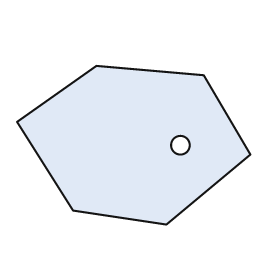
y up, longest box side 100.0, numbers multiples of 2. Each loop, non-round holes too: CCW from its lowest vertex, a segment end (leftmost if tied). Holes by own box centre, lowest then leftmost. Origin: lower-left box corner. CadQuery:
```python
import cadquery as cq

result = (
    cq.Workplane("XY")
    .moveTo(64.0, 0.0)
    .lineTo(100.0, 30.0)
    .lineTo(80.0, 64.0)
    .lineTo(34.0, 68.0)
    .lineTo(0.0, 44.0)
    .lineTo(24.0, 6.0)
    .close()
    .moveTo(70.0, 34.0)
    .circle(4.0)
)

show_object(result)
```